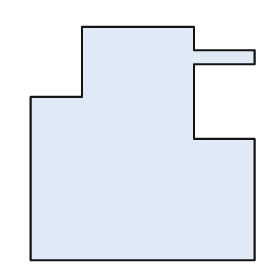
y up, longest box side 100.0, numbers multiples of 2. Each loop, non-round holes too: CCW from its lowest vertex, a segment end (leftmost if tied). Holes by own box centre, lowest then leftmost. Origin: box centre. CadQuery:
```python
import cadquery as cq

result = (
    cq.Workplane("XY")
    .moveTo(-48.0, -50.0)
    .lineTo(48.0, -50.0)
    .lineTo(48.0, 2.0)
    .lineTo(22.0, 2.0)
    .lineTo(22.0, 34.0)
    .lineTo(48.0, 34.0)
    .lineTo(48.0, 40.0)
    .lineTo(22.0, 40.0)
    .lineTo(22.0, 50.0)
    .lineTo(-26.0, 50.0)
    .lineTo(-26.0, 20.0)
    .lineTo(-48.0, 20.0)
    .close()
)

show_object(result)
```